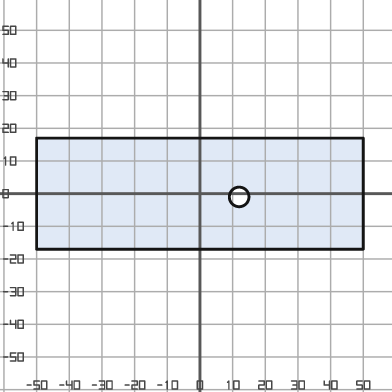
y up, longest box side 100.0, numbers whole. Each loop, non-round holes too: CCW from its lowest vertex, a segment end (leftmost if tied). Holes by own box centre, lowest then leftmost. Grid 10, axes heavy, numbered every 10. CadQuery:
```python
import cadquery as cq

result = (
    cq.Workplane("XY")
    .moveTo(-50.0, -17.0)
    .lineTo(50.0, -17.0)
    .lineTo(50.0, 17.0)
    .lineTo(-50.0, 17.0)
    .close()
    .moveTo(12.0, -1.0)
    .circle(3.0)
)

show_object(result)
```